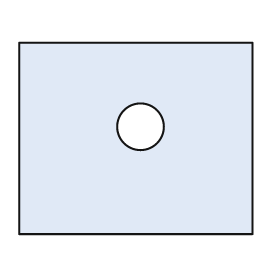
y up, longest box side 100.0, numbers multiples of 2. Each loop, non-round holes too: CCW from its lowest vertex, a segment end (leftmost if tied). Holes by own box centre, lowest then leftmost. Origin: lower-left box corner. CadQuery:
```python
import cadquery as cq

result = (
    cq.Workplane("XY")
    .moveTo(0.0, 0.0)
    .lineTo(100.0, 0.0)
    .lineTo(100.0, 82.0)
    .lineTo(0.0, 82.0)
    .close()
    .moveTo(52.0, 46.0)
    .circle(10.0)
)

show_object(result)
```